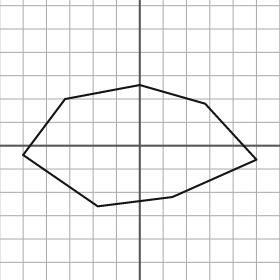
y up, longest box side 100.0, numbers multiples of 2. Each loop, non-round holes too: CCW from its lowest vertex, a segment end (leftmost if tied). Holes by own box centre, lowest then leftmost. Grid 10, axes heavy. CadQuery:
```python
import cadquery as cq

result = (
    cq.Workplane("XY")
    .moveTo(-18.0, -26.0)
    .lineTo(14.0, -22.0)
    .lineTo(50.0, -6.0)
    .lineTo(28.0, 18.0)
    .lineTo(0.0, 26.0)
    .lineTo(-32.0, 20.0)
    .lineTo(-50.0, -4.0)
    .close()
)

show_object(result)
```